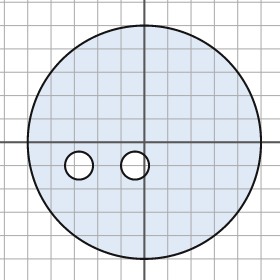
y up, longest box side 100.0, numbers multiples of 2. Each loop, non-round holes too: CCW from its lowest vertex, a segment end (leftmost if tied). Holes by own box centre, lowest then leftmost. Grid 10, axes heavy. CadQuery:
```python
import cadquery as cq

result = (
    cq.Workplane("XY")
    .moveTo(0.0, 0.0)
    .circle(50.0)
    .moveTo(-28.0, -10.0)
    .circle(6.0)
    .moveTo(-4.0, -10.0)
    .circle(6.0)
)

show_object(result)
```